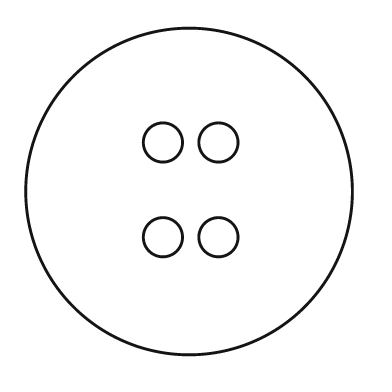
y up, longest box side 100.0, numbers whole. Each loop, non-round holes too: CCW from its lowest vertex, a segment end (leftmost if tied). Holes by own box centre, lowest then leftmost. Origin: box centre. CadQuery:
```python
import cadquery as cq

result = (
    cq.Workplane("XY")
    .moveTo(0.0, 0.0)
    .circle(50.0)
    .moveTo(-8.0, -14.0)
    .circle(6.0)
    .moveTo(9.0, -14.0)
    .circle(6.0)
    .moveTo(-8.0, 15.0)
    .circle(6.0)
    .moveTo(9.0, 15.0)
    .circle(6.0)
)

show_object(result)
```